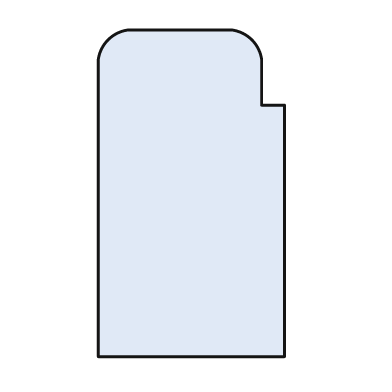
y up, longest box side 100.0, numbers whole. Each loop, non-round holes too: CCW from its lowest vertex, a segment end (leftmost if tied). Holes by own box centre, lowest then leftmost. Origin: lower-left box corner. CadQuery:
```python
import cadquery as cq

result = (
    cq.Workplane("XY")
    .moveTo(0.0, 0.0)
    .lineTo(57.0, 0.0)
    .lineTo(57.0, 77.0)
    .lineTo(50.0, 77.0)
    .lineTo(50.0, 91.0)
    .threePointArc((47.0, 97.0), (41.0, 100.0))
    .lineTo(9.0, 100.0)
    .threePointArc((3.0, 97.0), (0.0, 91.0))
    .close()
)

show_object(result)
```